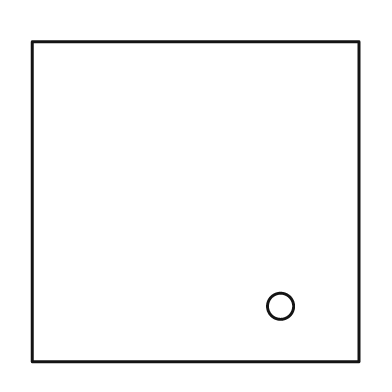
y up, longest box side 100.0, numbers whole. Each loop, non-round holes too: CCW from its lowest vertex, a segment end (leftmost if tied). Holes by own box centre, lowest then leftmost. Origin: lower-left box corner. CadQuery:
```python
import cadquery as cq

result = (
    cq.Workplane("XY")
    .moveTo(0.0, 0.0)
    .lineTo(100.0, 0.0)
    .lineTo(100.0, 98.0)
    .lineTo(0.0, 98.0)
    .close()
    .moveTo(76.0, 17.0)
    .circle(4.0)
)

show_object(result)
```